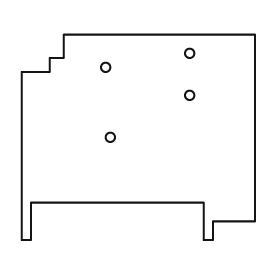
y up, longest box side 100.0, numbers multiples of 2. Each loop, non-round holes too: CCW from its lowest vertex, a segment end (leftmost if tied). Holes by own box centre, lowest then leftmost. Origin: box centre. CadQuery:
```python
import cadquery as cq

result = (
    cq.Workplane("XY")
    .moveTo(-50.0, -44.0)
    .lineTo(-46.0, -44.0)
    .lineTo(-46.0, -28.0)
    .lineTo(28.0, -28.0)
    .lineTo(28.0, -44.0)
    .lineTo(32.0, -44.0)
    .lineTo(32.0, -36.0)
    .lineTo(50.0, -36.0)
    .lineTo(50.0, 44.0)
    .lineTo(-32.0, 44.0)
    .lineTo(-32.0, 34.0)
    .lineTo(-38.0, 34.0)
    .lineTo(-38.0, 28.0)
    .lineTo(-50.0, 28.0)
    .close()
    .moveTo(-12.0, 0.0)
    .circle(2.0)
    .moveTo(22.0, 18.0)
    .circle(2.0)
    .moveTo(-14.0, 30.0)
    .circle(2.0)
    .moveTo(22.0, 36.0)
    .circle(2.0)
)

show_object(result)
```